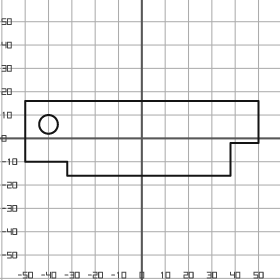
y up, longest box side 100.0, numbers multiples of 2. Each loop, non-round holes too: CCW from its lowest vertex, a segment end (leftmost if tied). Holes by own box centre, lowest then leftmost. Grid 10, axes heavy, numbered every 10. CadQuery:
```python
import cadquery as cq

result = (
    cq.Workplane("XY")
    .moveTo(-32.0, -16.0)
    .lineTo(38.0, -16.0)
    .lineTo(38.0, -2.0)
    .lineTo(50.0, -2.0)
    .lineTo(50.0, 16.0)
    .lineTo(-50.0, 16.0)
    .lineTo(-50.0, -10.0)
    .lineTo(-32.0, -10.0)
    .close()
    .moveTo(-40.0, 6.0)
    .circle(4.0)
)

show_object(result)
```